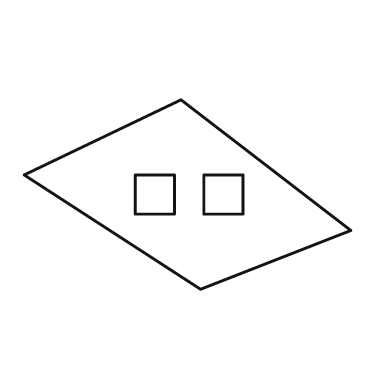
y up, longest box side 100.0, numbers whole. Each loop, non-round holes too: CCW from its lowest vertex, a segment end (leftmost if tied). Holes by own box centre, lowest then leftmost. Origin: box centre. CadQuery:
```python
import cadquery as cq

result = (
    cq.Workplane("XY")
    .moveTo(4.0, -29.0)
    .lineTo(50.0, -11.0)
    .lineTo(-2.0, 29.0)
    .lineTo(-50.0, 6.0)
    .close()
    .moveTo(-16.0, -6.0)
    .lineTo(-4.0, -6.0)
    .lineTo(-4.0, 6.0)
    .lineTo(-16.0, 6.0)
    .close()
    .moveTo(5.0, -6.0)
    .lineTo(17.0, -6.0)
    .lineTo(17.0, 6.0)
    .lineTo(5.0, 6.0)
    .close()
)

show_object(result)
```